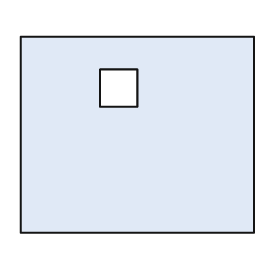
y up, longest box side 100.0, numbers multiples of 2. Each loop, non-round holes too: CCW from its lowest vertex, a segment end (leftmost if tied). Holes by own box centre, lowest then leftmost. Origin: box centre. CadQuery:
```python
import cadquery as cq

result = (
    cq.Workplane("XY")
    .moveTo(-50.0, -42.0)
    .lineTo(50.0, -42.0)
    .lineTo(50.0, 42.0)
    .lineTo(-50.0, 42.0)
    .close()
    .moveTo(-16.0, 12.0)
    .lineTo(0.0, 12.0)
    .lineTo(0.0, 28.0)
    .lineTo(-16.0, 28.0)
    .close()
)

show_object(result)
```